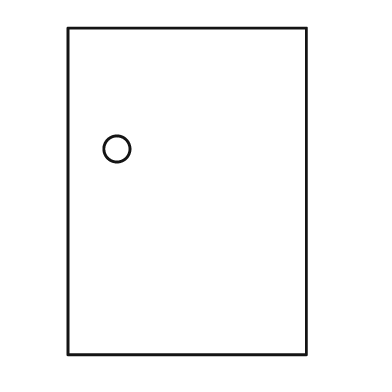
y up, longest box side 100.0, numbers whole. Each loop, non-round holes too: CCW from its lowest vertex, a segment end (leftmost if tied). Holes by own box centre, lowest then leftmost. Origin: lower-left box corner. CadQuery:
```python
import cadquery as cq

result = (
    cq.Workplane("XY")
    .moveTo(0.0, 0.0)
    .lineTo(73.0, 0.0)
    .lineTo(73.0, 100.0)
    .lineTo(0.0, 100.0)
    .close()
    .moveTo(15.0, 63.0)
    .circle(4.0)
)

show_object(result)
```